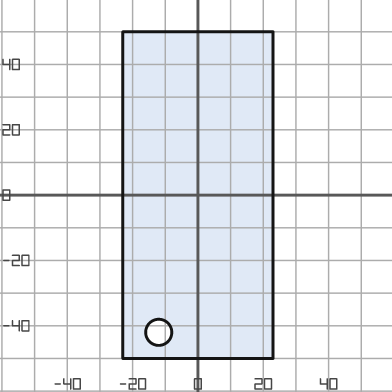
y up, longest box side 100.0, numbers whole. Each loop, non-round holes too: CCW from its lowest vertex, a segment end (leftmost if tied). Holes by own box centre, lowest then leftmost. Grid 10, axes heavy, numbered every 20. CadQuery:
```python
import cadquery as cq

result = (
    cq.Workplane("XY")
    .moveTo(-23.0, -50.0)
    .lineTo(23.0, -50.0)
    .lineTo(23.0, 50.0)
    .lineTo(-23.0, 50.0)
    .close()
    .moveTo(-12.0, -42.0)
    .circle(4.0)
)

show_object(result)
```